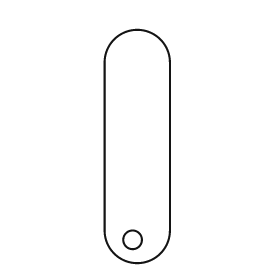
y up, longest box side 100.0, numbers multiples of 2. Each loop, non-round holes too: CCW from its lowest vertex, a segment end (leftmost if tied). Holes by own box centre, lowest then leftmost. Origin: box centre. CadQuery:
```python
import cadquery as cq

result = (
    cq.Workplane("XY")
    .moveTo(-14.0, -36.0)
    .threePointArc((0.0, -50.0), (14.0, -36.0))
    .lineTo(14.0, 36.0)
    .threePointArc((0.0, 50.0), (-14.0, 36.0))
    .close()
    .moveTo(-2.0, -40.0)
    .circle(4.0)
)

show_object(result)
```